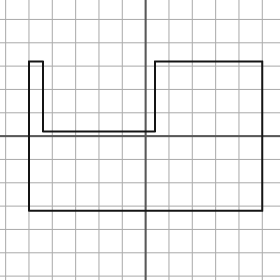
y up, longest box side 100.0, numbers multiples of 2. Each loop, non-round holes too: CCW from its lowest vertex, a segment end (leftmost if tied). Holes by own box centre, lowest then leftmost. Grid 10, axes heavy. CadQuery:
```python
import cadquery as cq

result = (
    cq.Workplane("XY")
    .moveTo(-50.0, -32.0)
    .lineTo(50.0, -32.0)
    .lineTo(50.0, 32.0)
    .lineTo(4.0, 32.0)
    .lineTo(4.0, 2.0)
    .lineTo(-44.0, 2.0)
    .lineTo(-44.0, 32.0)
    .lineTo(-50.0, 32.0)
    .close()
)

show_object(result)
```